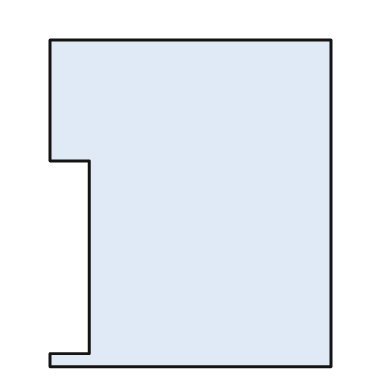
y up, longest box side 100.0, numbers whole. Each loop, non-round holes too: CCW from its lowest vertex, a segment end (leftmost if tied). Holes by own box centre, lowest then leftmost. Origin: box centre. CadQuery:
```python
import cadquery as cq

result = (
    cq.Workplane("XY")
    .moveTo(-43.0, -50.0)
    .lineTo(43.0, -50.0)
    .lineTo(43.0, 50.0)
    .lineTo(-43.0, 50.0)
    .lineTo(-43.0, 13.0)
    .lineTo(-31.0, 13.0)
    .lineTo(-31.0, -46.0)
    .lineTo(-43.0, -46.0)
    .close()
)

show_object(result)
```